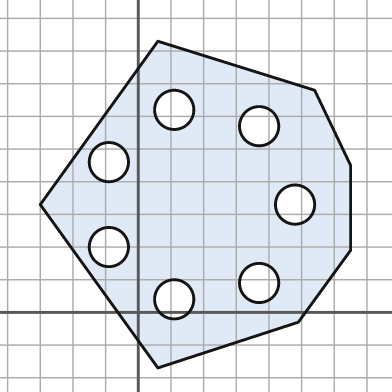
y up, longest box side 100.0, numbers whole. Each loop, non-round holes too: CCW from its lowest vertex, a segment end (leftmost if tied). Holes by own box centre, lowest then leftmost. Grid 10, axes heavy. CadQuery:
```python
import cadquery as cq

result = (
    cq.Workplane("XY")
    .moveTo(6.0, -17.0)
    .lineTo(49.0, -3.0)
    .lineTo(65.0, 19.0)
    .lineTo(65.0, 45.0)
    .lineTo(54.0, 68.0)
    .lineTo(6.0, 83.0)
    .lineTo(-30.0, 33.0)
    .close()
    .moveTo(11.0, 4.0)
    .circle(6.0)
    .moveTo(37.0, 9.0)
    .circle(6.0)
    .moveTo(-9.0, 20.0)
    .circle(6.0)
    .moveTo(48.0, 33.0)
    .circle(6.0)
    .moveTo(-9.0, 46.0)
    .circle(6.0)
    .moveTo(37.0, 57.0)
    .circle(6.0)
    .moveTo(11.0, 62.0)
    .circle(6.0)
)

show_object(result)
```